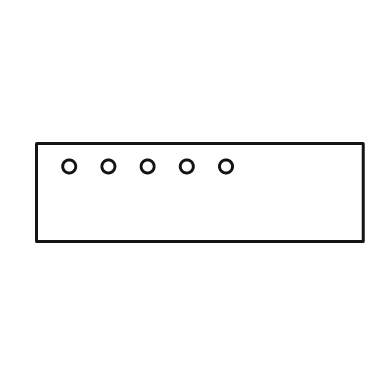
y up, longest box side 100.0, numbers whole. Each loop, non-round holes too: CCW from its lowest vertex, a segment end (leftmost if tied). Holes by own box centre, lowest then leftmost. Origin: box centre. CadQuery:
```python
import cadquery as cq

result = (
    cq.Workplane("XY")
    .moveTo(-50.0, -15.0)
    .lineTo(50.0, -15.0)
    .lineTo(50.0, 15.0)
    .lineTo(-50.0, 15.0)
    .close()
    .moveTo(-40.0, 8.0)
    .circle(2.0)
    .moveTo(-28.0, 8.0)
    .circle(2.0)
    .moveTo(-16.0, 8.0)
    .circle(2.0)
    .moveTo(-4.0, 8.0)
    .circle(2.0)
    .moveTo(8.0, 8.0)
    .circle(2.0)
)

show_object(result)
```